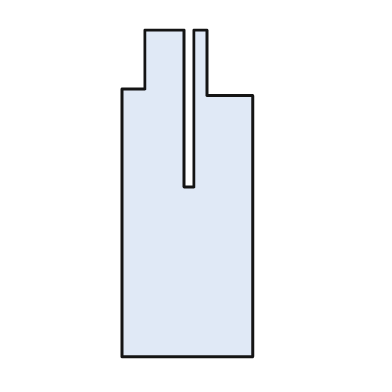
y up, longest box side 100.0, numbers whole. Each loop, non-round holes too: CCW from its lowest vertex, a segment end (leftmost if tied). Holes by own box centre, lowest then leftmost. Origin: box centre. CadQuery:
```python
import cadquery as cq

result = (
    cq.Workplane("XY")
    .moveTo(-20.0, -50.0)
    .lineTo(20.0, -50.0)
    .lineTo(20.0, 30.0)
    .lineTo(6.0, 30.0)
    .lineTo(6.0, 50.0)
    .lineTo(2.0, 50.0)
    .lineTo(2.0, 2.0)
    .lineTo(-1.0, 2.0)
    .lineTo(-1.0, 50.0)
    .lineTo(-13.0, 50.0)
    .lineTo(-13.0, 32.0)
    .lineTo(-20.0, 32.0)
    .close()
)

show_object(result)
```